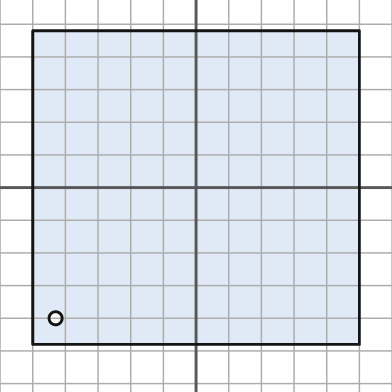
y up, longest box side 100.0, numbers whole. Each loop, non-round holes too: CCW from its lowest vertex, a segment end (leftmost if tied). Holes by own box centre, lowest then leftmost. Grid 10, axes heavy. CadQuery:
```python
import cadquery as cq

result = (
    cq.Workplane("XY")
    .moveTo(-50.0, -48.0)
    .lineTo(50.0, -48.0)
    .lineTo(50.0, 48.0)
    .lineTo(-50.0, 48.0)
    .close()
    .moveTo(-43.0, -40.0)
    .circle(2.0)
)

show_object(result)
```